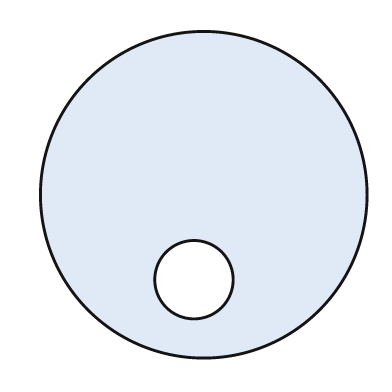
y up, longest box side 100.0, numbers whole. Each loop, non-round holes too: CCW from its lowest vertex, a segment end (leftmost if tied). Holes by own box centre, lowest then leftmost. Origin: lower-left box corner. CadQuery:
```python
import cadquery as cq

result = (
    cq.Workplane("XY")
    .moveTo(50.0, 50.0)
    .circle(50.0)
    .moveTo(47.0, 24.0)
    .circle(12.0)
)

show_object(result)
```